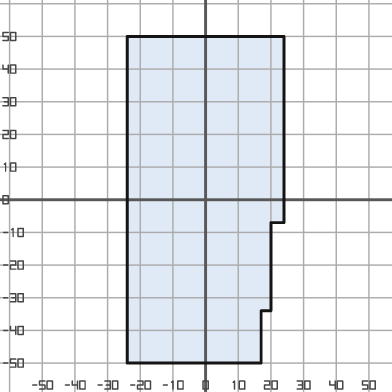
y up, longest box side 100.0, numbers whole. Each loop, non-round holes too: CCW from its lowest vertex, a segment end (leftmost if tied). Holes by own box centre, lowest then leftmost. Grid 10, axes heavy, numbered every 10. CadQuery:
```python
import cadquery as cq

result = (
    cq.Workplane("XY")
    .moveTo(-24.0, -50.0)
    .lineTo(17.0, -50.0)
    .lineTo(17.0, -34.0)
    .lineTo(20.0, -34.0)
    .lineTo(20.0, -7.0)
    .lineTo(24.0, -7.0)
    .lineTo(24.0, 50.0)
    .lineTo(-24.0, 50.0)
    .close()
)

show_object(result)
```